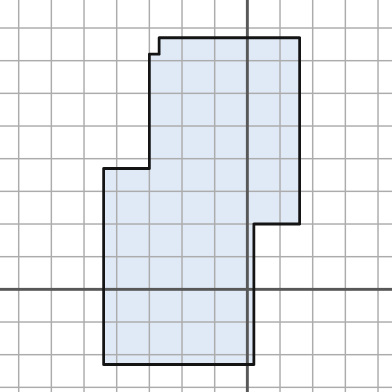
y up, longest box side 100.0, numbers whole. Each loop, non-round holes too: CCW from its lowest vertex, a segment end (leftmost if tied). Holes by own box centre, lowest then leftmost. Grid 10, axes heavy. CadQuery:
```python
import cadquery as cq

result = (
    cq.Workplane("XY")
    .moveTo(-44.0, -23.0)
    .lineTo(2.0, -23.0)
    .lineTo(2.0, 20.0)
    .lineTo(16.0, 20.0)
    .lineTo(16.0, 77.0)
    .lineTo(-27.0, 77.0)
    .lineTo(-27.0, 72.0)
    .lineTo(-30.0, 72.0)
    .lineTo(-30.0, 37.0)
    .lineTo(-44.0, 37.0)
    .close()
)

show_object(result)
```